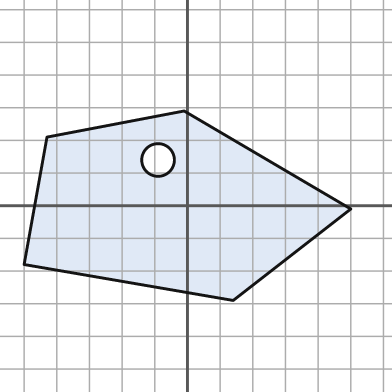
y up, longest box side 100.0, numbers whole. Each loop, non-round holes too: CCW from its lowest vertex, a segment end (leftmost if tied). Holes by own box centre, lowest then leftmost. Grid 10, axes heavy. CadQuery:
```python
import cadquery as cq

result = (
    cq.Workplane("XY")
    .moveTo(14.0, -29.0)
    .lineTo(50.0, -1.0)
    .lineTo(-1.0, 29.0)
    .lineTo(-43.0, 21.0)
    .lineTo(-50.0, -18.0)
    .close()
    .moveTo(-9.0, 14.0)
    .circle(5.0)
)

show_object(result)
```